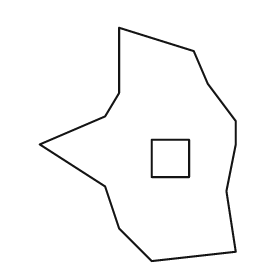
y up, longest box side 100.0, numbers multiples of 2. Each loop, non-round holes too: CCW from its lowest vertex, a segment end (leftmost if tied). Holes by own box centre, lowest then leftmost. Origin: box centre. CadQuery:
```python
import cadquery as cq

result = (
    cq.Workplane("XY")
    .moveTo(6.0, -50.0)
    .lineTo(42.0, -46.0)
    .lineTo(38.0, -20.0)
    .lineTo(42.0, 0.0)
    .lineTo(42.0, 10.0)
    .lineTo(30.0, 26.0)
    .lineTo(24.0, 40.0)
    .lineTo(-8.0, 50.0)
    .lineTo(-8.0, 22.0)
    .lineTo(-14.0, 12.0)
    .lineTo(-42.0, 0.0)
    .lineTo(-14.0, -18.0)
    .lineTo(-8.0, -36.0)
    .close()
    .moveTo(6.0, -14.0)
    .lineTo(22.0, -14.0)
    .lineTo(22.0, 2.0)
    .lineTo(6.0, 2.0)
    .close()
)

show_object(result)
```